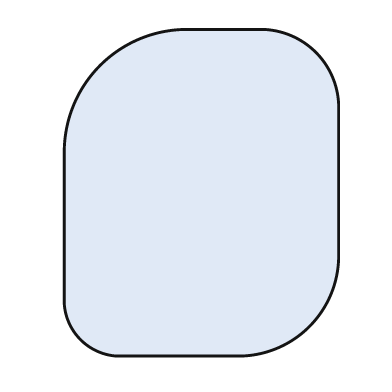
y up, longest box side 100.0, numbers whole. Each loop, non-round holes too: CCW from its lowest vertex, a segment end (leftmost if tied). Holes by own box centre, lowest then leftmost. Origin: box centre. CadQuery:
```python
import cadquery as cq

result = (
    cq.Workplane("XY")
    .moveTo(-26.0, -50.0)
    .lineTo(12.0, -50.0)
    .threePointArc((33.0, -41.0), (42.0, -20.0))
    .lineTo(42.0, 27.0)
    .threePointArc((35.0, 43.0), (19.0, 50.0))
    .lineTo(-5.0, 50.0)
    .threePointArc((-31.0, 39.0), (-42.0, 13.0))
    .lineTo(-42.0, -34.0)
    .threePointArc((-37.0, -45.0), (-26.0, -50.0))
    .close()
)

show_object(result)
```